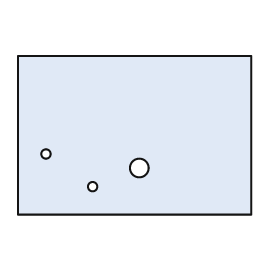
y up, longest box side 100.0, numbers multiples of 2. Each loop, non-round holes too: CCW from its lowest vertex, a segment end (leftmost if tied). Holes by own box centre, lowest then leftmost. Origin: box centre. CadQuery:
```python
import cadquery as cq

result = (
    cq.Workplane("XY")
    .moveTo(-50.0, -34.0)
    .lineTo(50.0, -34.0)
    .lineTo(50.0, 34.0)
    .lineTo(-50.0, 34.0)
    .close()
    .moveTo(-18.0, -22.0)
    .circle(2.0)
    .moveTo(2.0, -14.0)
    .circle(4.0)
    .moveTo(-38.0, -8.0)
    .circle(2.0)
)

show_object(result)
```